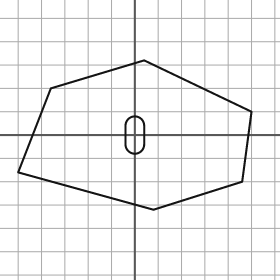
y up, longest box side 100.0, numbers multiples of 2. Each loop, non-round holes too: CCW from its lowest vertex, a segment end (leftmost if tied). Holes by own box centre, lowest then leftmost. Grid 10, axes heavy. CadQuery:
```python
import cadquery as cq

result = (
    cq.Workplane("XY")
    .moveTo(8.0, -32.0)
    .lineTo(46.0, -20.0)
    .lineTo(50.0, 10.0)
    .lineTo(4.0, 32.0)
    .lineTo(-36.0, 20.0)
    .lineTo(-50.0, -16.0)
    .close()
    .moveTo(-4.0, -4.0)
    .threePointArc((0.0, -8.0), (4.0, -4.0))
    .lineTo(4.0, 4.0)
    .threePointArc((0.0, 8.0), (-4.0, 4.0))
    .close()
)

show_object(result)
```